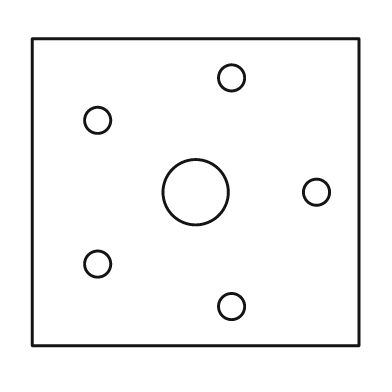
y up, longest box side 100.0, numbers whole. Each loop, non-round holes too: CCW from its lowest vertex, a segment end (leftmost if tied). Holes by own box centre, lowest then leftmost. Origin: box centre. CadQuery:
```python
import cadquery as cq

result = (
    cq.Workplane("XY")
    .moveTo(-50.0, -47.0)
    .lineTo(50.0, -47.0)
    .lineTo(50.0, 47.0)
    .lineTo(-50.0, 47.0)
    .close()
    .moveTo(11.0, -35.0)
    .circle(4.0)
    .moveTo(-30.0, -22.0)
    .circle(4.0)
    .moveTo(0.0, 0.0)
    .circle(10.0)
    .moveTo(37.0, 0.0)
    .circle(4.0)
    .moveTo(-30.0, 22.0)
    .circle(4.0)
    .moveTo(11.0, 35.0)
    .circle(4.0)
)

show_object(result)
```